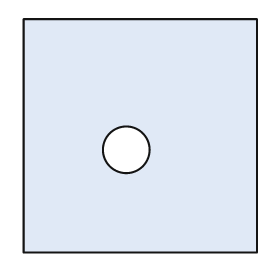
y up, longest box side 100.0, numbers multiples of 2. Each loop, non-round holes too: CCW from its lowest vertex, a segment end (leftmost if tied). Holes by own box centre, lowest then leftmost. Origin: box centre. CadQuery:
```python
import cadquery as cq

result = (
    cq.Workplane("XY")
    .moveTo(-50.0, -50.0)
    .lineTo(50.0, -50.0)
    .lineTo(50.0, 50.0)
    .lineTo(-50.0, 50.0)
    .close()
    .moveTo(-6.0, -6.0)
    .circle(10.0)
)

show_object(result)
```